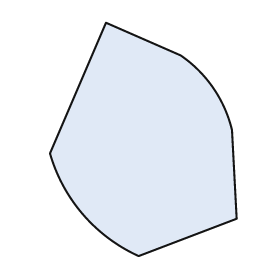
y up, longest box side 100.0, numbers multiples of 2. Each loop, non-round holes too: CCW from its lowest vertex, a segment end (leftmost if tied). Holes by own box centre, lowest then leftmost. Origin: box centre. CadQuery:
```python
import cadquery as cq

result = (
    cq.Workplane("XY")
    .moveTo(-2.0, -50.0)
    .lineTo(40.0, -34.0)
    .lineTo(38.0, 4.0)
    .threePointArc((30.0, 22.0), (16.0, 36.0))
    .lineTo(-16.0, 50.0)
    .lineTo(-40.0, -6.0)
    .threePointArc((-26.0, -32.0), (-2.0, -50.0))
    .close()
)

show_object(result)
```